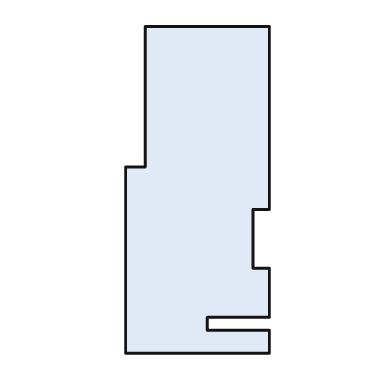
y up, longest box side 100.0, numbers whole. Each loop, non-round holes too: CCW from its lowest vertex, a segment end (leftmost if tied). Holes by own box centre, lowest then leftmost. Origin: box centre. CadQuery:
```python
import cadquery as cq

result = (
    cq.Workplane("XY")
    .moveTo(-22.0, -50.0)
    .lineTo(22.0, -50.0)
    .lineTo(22.0, -43.0)
    .lineTo(3.0, -43.0)
    .lineTo(3.0, -39.0)
    .lineTo(22.0, -39.0)
    .lineTo(22.0, -24.0)
    .lineTo(17.0, -24.0)
    .lineTo(17.0, -6.0)
    .lineTo(22.0, -6.0)
    .lineTo(22.0, 50.0)
    .lineTo(-16.0, 50.0)
    .lineTo(-16.0, 7.0)
    .lineTo(-22.0, 7.0)
    .close()
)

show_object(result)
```